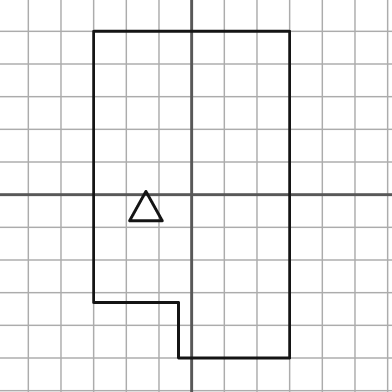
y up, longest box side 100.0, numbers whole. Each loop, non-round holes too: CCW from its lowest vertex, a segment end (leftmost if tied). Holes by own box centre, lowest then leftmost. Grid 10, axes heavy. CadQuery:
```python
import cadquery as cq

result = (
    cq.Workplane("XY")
    .moveTo(-4.0, -50.0)
    .lineTo(30.0, -50.0)
    .lineTo(30.0, 50.0)
    .lineTo(-30.0, 50.0)
    .lineTo(-30.0, -33.0)
    .lineTo(-4.0, -33.0)
    .close()
    .moveTo(-19.0, -8.0)
    .lineTo(-9.0, -8.0)
    .lineTo(-14.0, 1.0)
    .close()
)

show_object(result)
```